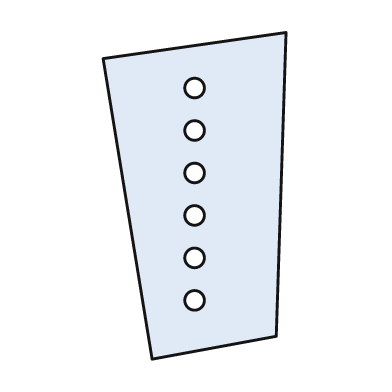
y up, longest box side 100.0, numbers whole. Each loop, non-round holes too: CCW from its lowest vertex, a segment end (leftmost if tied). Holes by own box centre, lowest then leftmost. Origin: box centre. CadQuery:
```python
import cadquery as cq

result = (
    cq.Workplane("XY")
    .moveTo(-13.0, -50.0)
    .lineTo(25.0, -43.0)
    .lineTo(28.0, 50.0)
    .lineTo(-28.0, 42.0)
    .close()
    .moveTo(0.0, -32.0)
    .circle(3.0)
    .moveTo(0.0, -19.0)
    .circle(3.0)
    .moveTo(0.0, -6.0)
    .circle(3.0)
    .moveTo(0.0, 7.0)
    .circle(3.0)
    .moveTo(0.0, 20.0)
    .circle(3.0)
    .moveTo(0.0, 33.0)
    .circle(3.0)
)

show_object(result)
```